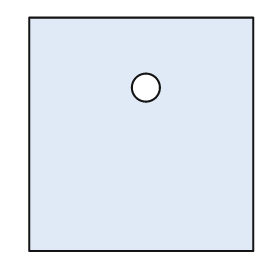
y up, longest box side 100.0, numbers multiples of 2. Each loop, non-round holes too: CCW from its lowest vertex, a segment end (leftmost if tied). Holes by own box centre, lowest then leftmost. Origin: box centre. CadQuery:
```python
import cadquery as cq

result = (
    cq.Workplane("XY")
    .moveTo(-48.0, -50.0)
    .lineTo(48.0, -50.0)
    .lineTo(48.0, 50.0)
    .lineTo(-48.0, 50.0)
    .close()
    .moveTo(2.0, 20.0)
    .circle(6.0)
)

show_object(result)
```